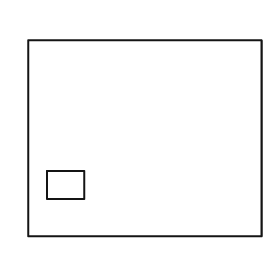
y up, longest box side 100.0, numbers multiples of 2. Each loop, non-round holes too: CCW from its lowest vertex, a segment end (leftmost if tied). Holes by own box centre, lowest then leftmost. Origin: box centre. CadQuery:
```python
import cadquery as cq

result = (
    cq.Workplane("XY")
    .moveTo(-50.0, -42.0)
    .lineTo(50.0, -42.0)
    .lineTo(50.0, 42.0)
    .lineTo(-50.0, 42.0)
    .close()
    .moveTo(-42.0, -26.0)
    .lineTo(-26.0, -26.0)
    .lineTo(-26.0, -14.0)
    .lineTo(-42.0, -14.0)
    .close()
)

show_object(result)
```